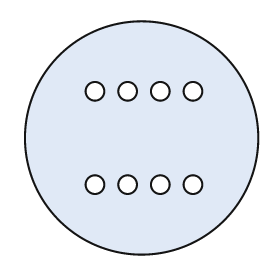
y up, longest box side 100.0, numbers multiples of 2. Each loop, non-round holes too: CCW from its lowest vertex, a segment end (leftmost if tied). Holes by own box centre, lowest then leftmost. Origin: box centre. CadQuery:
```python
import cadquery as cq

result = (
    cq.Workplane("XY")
    .moveTo(0.0, 0.0)
    .circle(50.0)
    .moveTo(-20.0, -20.0)
    .circle(4.0)
    .moveTo(-6.0, -20.0)
    .circle(4.0)
    .moveTo(8.0, -20.0)
    .circle(4.0)
    .moveTo(22.0, -20.0)
    .circle(4.0)
    .moveTo(-20.0, 20.0)
    .circle(4.0)
    .moveTo(-6.0, 20.0)
    .circle(4.0)
    .moveTo(8.0, 20.0)
    .circle(4.0)
    .moveTo(22.0, 20.0)
    .circle(4.0)
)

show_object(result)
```